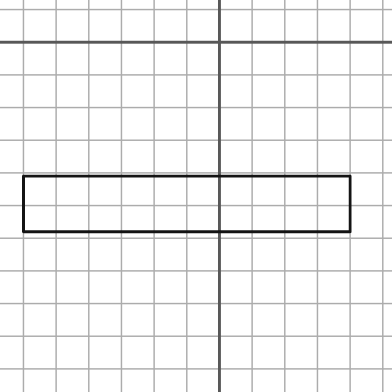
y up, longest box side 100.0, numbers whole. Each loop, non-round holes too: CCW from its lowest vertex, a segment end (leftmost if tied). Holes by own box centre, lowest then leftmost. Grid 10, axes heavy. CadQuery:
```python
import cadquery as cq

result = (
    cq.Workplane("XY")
    .moveTo(-60.0, -58.0)
    .lineTo(40.0, -58.0)
    .lineTo(40.0, -41.0)
    .lineTo(-60.0, -41.0)
    .close()
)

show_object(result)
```